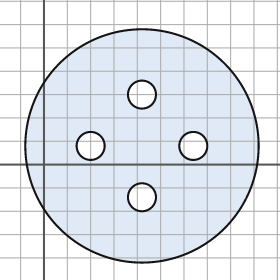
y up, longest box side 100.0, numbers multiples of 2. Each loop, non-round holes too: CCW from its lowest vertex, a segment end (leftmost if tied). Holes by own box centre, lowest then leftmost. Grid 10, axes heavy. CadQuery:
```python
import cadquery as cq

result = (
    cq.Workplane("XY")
    .moveTo(42.0, 8.0)
    .circle(50.0)
    .moveTo(42.0, -14.0)
    .circle(6.0)
    .moveTo(20.0, 8.0)
    .circle(6.0)
    .moveTo(64.0, 8.0)
    .circle(6.0)
    .moveTo(42.0, 30.0)
    .circle(6.0)
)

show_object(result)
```